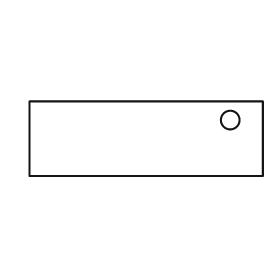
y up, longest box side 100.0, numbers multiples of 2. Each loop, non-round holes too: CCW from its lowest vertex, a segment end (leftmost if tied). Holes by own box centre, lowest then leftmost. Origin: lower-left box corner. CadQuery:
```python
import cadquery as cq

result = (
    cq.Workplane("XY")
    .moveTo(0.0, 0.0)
    .lineTo(100.0, 0.0)
    .lineTo(100.0, 32.0)
    .lineTo(0.0, 32.0)
    .close()
    .moveTo(86.0, 24.0)
    .circle(4.0)
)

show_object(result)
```